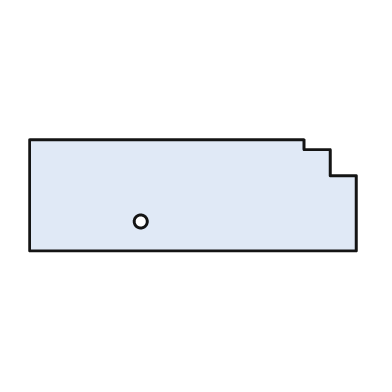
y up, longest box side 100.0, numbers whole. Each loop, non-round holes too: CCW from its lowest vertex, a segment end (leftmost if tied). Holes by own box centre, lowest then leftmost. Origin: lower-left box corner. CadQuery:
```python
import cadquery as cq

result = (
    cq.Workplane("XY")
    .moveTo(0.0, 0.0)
    .lineTo(100.0, 0.0)
    .lineTo(100.0, 23.0)
    .lineTo(92.0, 23.0)
    .lineTo(92.0, 31.0)
    .lineTo(84.0, 31.0)
    .lineTo(84.0, 34.0)
    .lineTo(0.0, 34.0)
    .close()
    .moveTo(34.0, 9.0)
    .circle(2.0)
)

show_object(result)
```